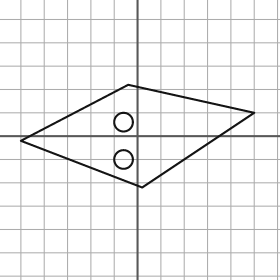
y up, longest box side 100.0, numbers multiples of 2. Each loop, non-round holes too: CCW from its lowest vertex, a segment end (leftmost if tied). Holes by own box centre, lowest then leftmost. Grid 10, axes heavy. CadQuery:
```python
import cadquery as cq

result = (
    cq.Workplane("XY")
    .moveTo(2.0, -22.0)
    .lineTo(50.0, 10.0)
    .lineTo(-4.0, 22.0)
    .lineTo(-50.0, -2.0)
    .close()
    .moveTo(-6.0, -10.0)
    .circle(4.0)
    .moveTo(-6.0, 6.0)
    .circle(4.0)
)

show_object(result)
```